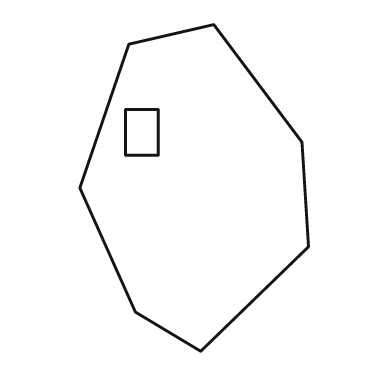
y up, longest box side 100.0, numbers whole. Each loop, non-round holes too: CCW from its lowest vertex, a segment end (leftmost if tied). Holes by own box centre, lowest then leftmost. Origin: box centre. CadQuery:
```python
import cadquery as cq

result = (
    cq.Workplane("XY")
    .moveTo(2.0, -50.0)
    .lineTo(35.0, -18.0)
    .lineTo(33.0, 14.0)
    .lineTo(6.0, 50.0)
    .lineTo(-20.0, 44.0)
    .lineTo(-35.0, 0.0)
    .lineTo(-18.0, -38.0)
    .close()
    .moveTo(-21.0, 10.0)
    .lineTo(-11.0, 10.0)
    .lineTo(-11.0, 24.0)
    .lineTo(-21.0, 24.0)
    .close()
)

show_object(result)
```